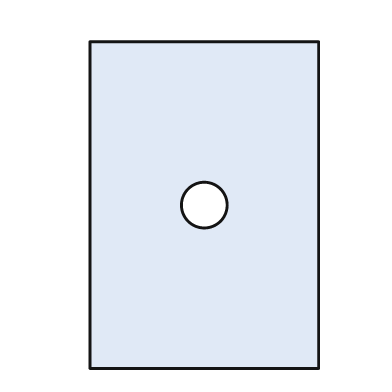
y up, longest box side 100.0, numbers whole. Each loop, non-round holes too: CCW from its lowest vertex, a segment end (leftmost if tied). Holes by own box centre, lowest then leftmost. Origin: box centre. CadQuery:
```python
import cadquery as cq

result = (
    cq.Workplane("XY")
    .moveTo(-35.0, -50.0)
    .lineTo(35.0, -50.0)
    .lineTo(35.0, 50.0)
    .lineTo(-35.0, 50.0)
    .close()
    .moveTo(0.0, 0.0)
    .circle(7.0)
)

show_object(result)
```